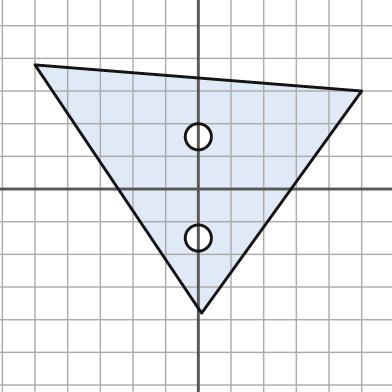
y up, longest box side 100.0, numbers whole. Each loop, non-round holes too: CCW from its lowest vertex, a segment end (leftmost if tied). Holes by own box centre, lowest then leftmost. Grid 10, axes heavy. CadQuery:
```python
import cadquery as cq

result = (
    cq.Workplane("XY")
    .moveTo(1.0, -38.0)
    .lineTo(50.0, 30.0)
    .lineTo(-50.0, 38.0)
    .close()
    .moveTo(0.0, -15.0)
    .circle(4.0)
    .moveTo(0.0, 16.0)
    .circle(4.0)
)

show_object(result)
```